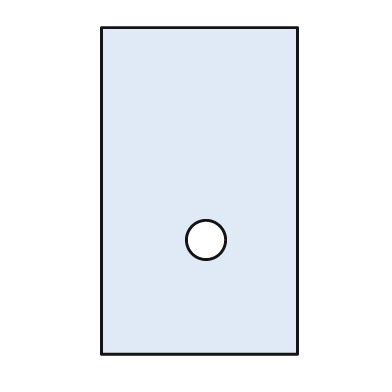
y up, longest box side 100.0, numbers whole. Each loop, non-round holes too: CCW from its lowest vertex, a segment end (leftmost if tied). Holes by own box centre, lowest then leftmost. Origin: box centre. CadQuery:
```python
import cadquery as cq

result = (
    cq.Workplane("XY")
    .moveTo(-30.0, -50.0)
    .lineTo(30.0, -50.0)
    .lineTo(30.0, 50.0)
    .lineTo(-30.0, 50.0)
    .close()
    .moveTo(2.0, -15.0)
    .circle(6.0)
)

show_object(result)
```